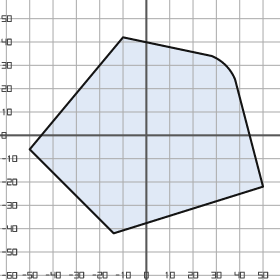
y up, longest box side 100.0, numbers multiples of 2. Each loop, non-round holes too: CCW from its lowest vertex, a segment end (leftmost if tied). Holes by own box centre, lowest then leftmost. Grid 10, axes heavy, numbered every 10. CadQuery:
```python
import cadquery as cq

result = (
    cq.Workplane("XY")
    .moveTo(-14.0, -42.0)
    .lineTo(50.0, -22.0)
    .lineTo(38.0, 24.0)
    .threePointArc((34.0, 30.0), (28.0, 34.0))
    .lineTo(-10.0, 42.0)
    .lineTo(-50.0, -6.0)
    .close()
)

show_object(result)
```